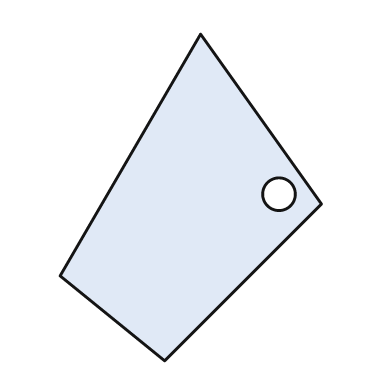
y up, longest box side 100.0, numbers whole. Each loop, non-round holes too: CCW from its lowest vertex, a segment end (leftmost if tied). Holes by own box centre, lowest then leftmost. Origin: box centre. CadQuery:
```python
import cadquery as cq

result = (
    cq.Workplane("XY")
    .moveTo(-8.0, -50.0)
    .lineTo(40.0, -2.0)
    .lineTo(3.0, 50.0)
    .lineTo(-40.0, -24.0)
    .close()
    .moveTo(27.0, 1.0)
    .circle(5.0)
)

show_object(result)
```